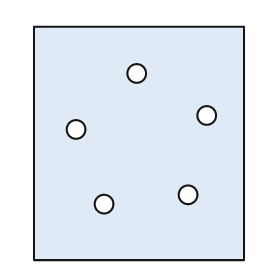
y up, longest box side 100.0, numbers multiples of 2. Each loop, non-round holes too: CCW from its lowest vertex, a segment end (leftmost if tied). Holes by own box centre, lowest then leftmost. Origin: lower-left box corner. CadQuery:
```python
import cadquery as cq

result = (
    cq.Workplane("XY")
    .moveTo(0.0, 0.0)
    .lineTo(90.0, 0.0)
    .lineTo(90.0, 100.0)
    .lineTo(0.0, 100.0)
    .close()
    .moveTo(30.0, 24.0)
    .circle(4.0)
    .moveTo(66.0, 28.0)
    .circle(4.0)
    .moveTo(18.0, 56.0)
    .circle(4.0)
    .moveTo(74.0, 62.0)
    .circle(4.0)
    .moveTo(44.0, 80.0)
    .circle(4.0)
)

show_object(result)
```